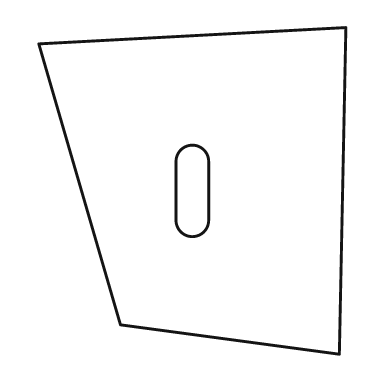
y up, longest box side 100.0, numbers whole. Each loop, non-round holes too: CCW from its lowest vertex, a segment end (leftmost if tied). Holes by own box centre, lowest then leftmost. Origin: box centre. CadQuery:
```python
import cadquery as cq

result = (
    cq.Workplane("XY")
    .moveTo(45.0, -50.0)
    .lineTo(47.0, 50.0)
    .lineTo(-47.0, 45.0)
    .lineTo(-22.0, -41.0)
    .close()
    .moveTo(-5.0, -9.0)
    .threePointArc((0.0, -14.0), (5.0, -9.0))
    .lineTo(5.0, 9.0)
    .threePointArc((0.0, 14.0), (-5.0, 9.0))
    .close()
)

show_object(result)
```